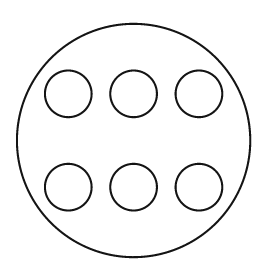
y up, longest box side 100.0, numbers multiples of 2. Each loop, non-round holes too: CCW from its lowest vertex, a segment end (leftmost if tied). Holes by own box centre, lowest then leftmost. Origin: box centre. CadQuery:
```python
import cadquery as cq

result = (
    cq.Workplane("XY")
    .moveTo(0.0, 0.0)
    .circle(50.0)
    .moveTo(-28.0, -20.0)
    .circle(10.0)
    .moveTo(0.0, -20.0)
    .circle(10.0)
    .moveTo(28.0, -20.0)
    .circle(10.0)
    .moveTo(-28.0, 20.0)
    .circle(10.0)
    .moveTo(0.0, 20.0)
    .circle(10.0)
    .moveTo(28.0, 20.0)
    .circle(10.0)
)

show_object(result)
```